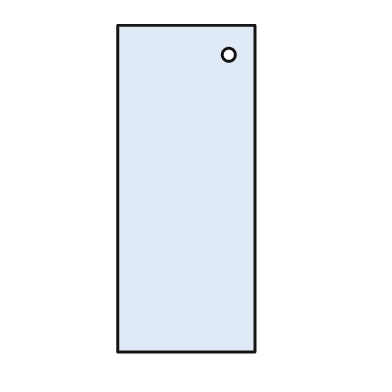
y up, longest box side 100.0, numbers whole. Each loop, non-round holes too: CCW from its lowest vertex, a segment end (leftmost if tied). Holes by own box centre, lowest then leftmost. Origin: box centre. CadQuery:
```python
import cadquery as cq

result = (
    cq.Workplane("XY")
    .moveTo(-21.0, -50.0)
    .lineTo(21.0, -50.0)
    .lineTo(21.0, 50.0)
    .lineTo(-21.0, 50.0)
    .close()
    .moveTo(13.0, 41.0)
    .circle(2.0)
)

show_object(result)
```